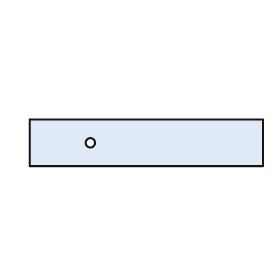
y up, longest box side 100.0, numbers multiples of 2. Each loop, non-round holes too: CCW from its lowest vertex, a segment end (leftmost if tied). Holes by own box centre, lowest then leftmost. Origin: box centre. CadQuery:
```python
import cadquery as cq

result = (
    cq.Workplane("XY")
    .moveTo(-50.0, -10.0)
    .lineTo(50.0, -10.0)
    .lineTo(50.0, 10.0)
    .lineTo(-50.0, 10.0)
    .close()
    .moveTo(-24.0, 0.0)
    .circle(2.0)
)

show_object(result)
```